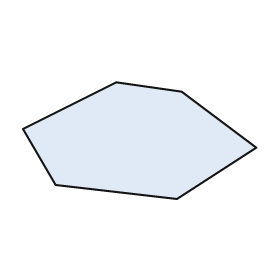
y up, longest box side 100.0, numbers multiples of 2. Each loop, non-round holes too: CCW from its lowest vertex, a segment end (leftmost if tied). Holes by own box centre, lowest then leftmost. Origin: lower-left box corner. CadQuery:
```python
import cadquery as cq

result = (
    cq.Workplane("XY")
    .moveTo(66.0, 0.0)
    .lineTo(100.0, 22.0)
    .lineTo(68.0, 46.0)
    .lineTo(40.0, 50.0)
    .lineTo(0.0, 30.0)
    .lineTo(14.0, 6.0)
    .close()
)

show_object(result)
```